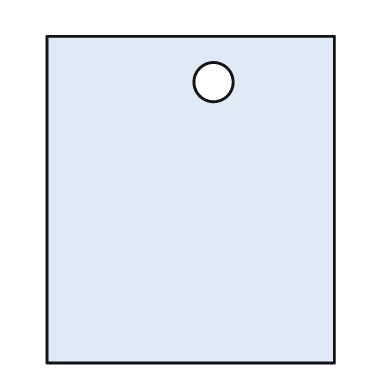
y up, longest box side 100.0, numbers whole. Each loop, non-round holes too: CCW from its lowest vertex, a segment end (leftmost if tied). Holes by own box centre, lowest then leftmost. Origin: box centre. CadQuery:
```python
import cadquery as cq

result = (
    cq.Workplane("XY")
    .moveTo(-44.0, -50.0)
    .lineTo(44.0, -50.0)
    .lineTo(44.0, 50.0)
    .lineTo(-44.0, 50.0)
    .close()
    .moveTo(7.0, 36.0)
    .circle(6.0)
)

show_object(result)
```